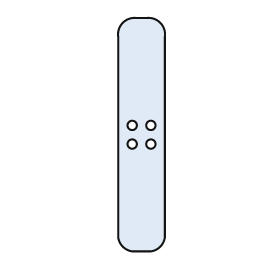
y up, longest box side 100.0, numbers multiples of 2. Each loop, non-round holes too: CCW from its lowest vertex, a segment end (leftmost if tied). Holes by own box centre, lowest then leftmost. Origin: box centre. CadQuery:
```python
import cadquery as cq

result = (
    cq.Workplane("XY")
    .moveTo(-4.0, -50.0)
    .lineTo(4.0, -50.0)
    .threePointArc((8.0, -48.0), (10.0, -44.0))
    .lineTo(10.0, 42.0)
    .threePointArc((8.0, 48.0), (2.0, 50.0))
    .lineTo(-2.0, 50.0)
    .threePointArc((-8.0, 48.0), (-10.0, 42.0))
    .lineTo(-10.0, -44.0)
    .threePointArc((-8.0, -48.0), (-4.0, -50.0))
    .close()
    .moveTo(-4.0, -4.0)
    .circle(2.0)
    .moveTo(4.0, -4.0)
    .circle(2.0)
    .moveTo(-4.0, 4.0)
    .circle(2.0)
    .moveTo(4.0, 4.0)
    .circle(2.0)
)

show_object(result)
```